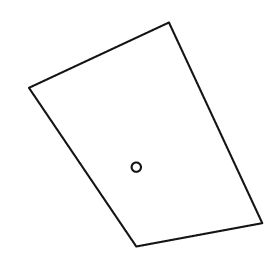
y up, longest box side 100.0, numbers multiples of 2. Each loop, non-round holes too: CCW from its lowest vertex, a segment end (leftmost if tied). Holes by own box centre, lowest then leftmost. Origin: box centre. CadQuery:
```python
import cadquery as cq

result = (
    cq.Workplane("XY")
    .moveTo(-4.0, -48.0)
    .lineTo(50.0, -38.0)
    .lineTo(10.0, 48.0)
    .lineTo(-50.0, 20.0)
    .close()
    .moveTo(-4.0, -14.0)
    .circle(2.0)
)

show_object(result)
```